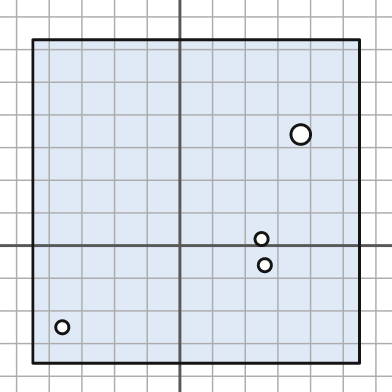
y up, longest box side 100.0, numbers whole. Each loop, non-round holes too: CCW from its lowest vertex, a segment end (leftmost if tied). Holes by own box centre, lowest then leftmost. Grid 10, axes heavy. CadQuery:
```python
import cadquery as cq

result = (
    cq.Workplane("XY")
    .moveTo(-45.0, -36.0)
    .lineTo(55.0, -36.0)
    .lineTo(55.0, 63.0)
    .lineTo(-45.0, 63.0)
    .close()
    .moveTo(-36.0, -25.0)
    .circle(2.0)
    .moveTo(26.0, -6.0)
    .circle(2.0)
    .moveTo(25.0, 2.0)
    .circle(2.0)
    .moveTo(37.0, 34.0)
    .circle(3.0)
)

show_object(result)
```